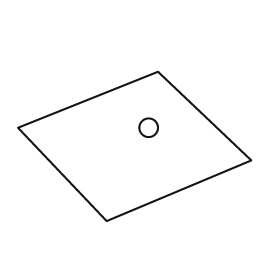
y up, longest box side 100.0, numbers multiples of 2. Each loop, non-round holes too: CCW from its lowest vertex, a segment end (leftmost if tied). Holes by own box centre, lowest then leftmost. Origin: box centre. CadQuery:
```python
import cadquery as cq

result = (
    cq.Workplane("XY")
    .moveTo(-12.0, -32.0)
    .lineTo(50.0, -6.0)
    .lineTo(10.0, 32.0)
    .lineTo(-50.0, 8.0)
    .close()
    .moveTo(6.0, 8.0)
    .circle(4.0)
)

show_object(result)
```